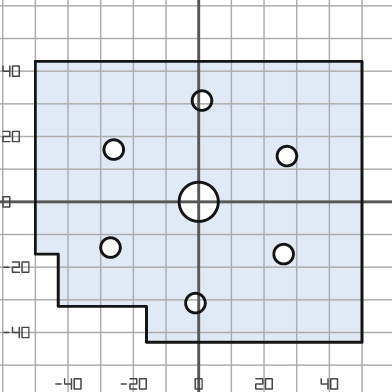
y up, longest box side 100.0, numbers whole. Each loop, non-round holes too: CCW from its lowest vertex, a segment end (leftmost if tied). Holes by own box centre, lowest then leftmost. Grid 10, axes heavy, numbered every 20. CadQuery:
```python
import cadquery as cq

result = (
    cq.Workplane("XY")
    .moveTo(-16.0, -43.0)
    .lineTo(50.0, -43.0)
    .lineTo(50.0, 43.0)
    .lineTo(-50.0, 43.0)
    .lineTo(-50.0, -16.0)
    .lineTo(-43.0, -16.0)
    .lineTo(-43.0, -32.0)
    .lineTo(-16.0, -32.0)
    .close()
    .moveTo(-1.0, -31.0)
    .circle(3.0)
    .moveTo(26.0, -16.0)
    .circle(3.0)
    .moveTo(-27.0, -14.0)
    .circle(3.0)
    .moveTo(0.0, 0.0)
    .circle(6.0)
    .moveTo(27.0, 14.0)
    .circle(3.0)
    .moveTo(-26.0, 16.0)
    .circle(3.0)
    .moveTo(1.0, 31.0)
    .circle(3.0)
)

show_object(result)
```